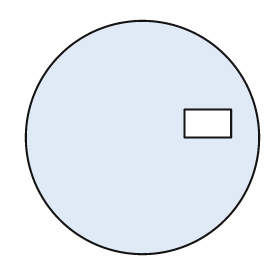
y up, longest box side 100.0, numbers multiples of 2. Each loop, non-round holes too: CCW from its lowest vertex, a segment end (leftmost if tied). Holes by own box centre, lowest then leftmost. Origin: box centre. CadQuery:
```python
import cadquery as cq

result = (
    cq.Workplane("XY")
    .moveTo(0.0, 0.0)
    .circle(50.0)
    .moveTo(18.0, 0.0)
    .lineTo(38.0, 0.0)
    .lineTo(38.0, 12.0)
    .lineTo(18.0, 12.0)
    .close()
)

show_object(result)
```